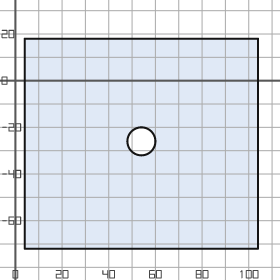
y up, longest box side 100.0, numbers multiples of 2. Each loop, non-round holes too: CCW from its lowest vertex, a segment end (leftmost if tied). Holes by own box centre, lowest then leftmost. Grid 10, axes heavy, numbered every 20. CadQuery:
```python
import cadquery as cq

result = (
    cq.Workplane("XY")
    .moveTo(4.0, -72.0)
    .lineTo(104.0, -72.0)
    .lineTo(104.0, 18.0)
    .lineTo(4.0, 18.0)
    .close()
    .moveTo(54.0, -26.0)
    .circle(6.0)
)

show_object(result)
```